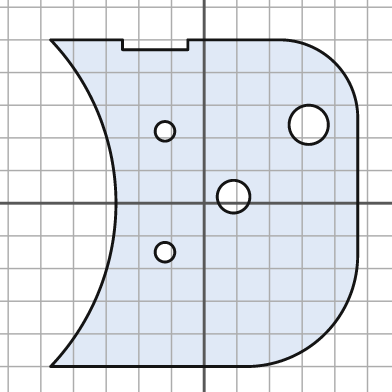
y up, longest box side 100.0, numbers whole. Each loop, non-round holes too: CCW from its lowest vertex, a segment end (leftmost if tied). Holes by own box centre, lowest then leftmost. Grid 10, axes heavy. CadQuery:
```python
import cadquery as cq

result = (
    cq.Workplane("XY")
    .moveTo(-47.0, -50.0)
    .lineTo(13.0, -50.0)
    .threePointArc((37.0, -40.0), (47.0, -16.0))
    .lineTo(47.0, 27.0)
    .threePointArc((40.0, 43.0), (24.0, 50.0))
    .lineTo(-5.0, 50.0)
    .lineTo(-5.0, 47.0)
    .lineTo(-25.0, 47.0)
    .lineTo(-25.0, 50.0)
    .lineTo(-47.0, 50.0)
    .threePointArc((-27.0, 0.0), (-47.0, -50.0))
    .close()
    .moveTo(-12.0, -15.0)
    .circle(3.0)
    .moveTo(9.0, 2.0)
    .circle(5.0)
    .moveTo(-12.0, 22.0)
    .circle(3.0)
    .moveTo(32.0, 24.0)
    .circle(6.0)
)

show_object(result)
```